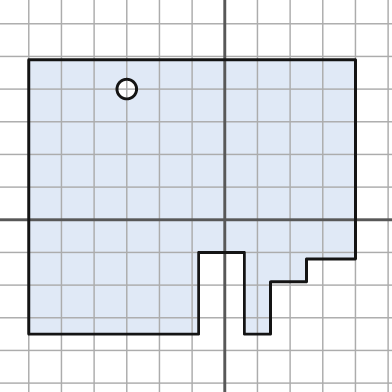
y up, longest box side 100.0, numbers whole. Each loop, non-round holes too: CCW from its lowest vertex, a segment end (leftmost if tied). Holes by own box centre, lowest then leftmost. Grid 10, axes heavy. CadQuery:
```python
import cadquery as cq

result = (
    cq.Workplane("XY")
    .moveTo(-60.0, -35.0)
    .lineTo(-8.0, -35.0)
    .lineTo(-8.0, -10.0)
    .lineTo(6.0, -10.0)
    .lineTo(6.0, -35.0)
    .lineTo(14.0, -35.0)
    .lineTo(14.0, -19.0)
    .lineTo(25.0, -19.0)
    .lineTo(25.0, -12.0)
    .lineTo(40.0, -12.0)
    .lineTo(40.0, 49.0)
    .lineTo(-60.0, 49.0)
    .close()
    .moveTo(-30.0, 40.0)
    .circle(3.0)
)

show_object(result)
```